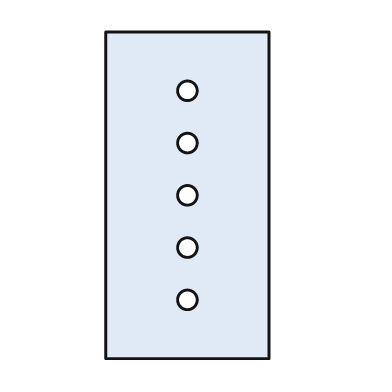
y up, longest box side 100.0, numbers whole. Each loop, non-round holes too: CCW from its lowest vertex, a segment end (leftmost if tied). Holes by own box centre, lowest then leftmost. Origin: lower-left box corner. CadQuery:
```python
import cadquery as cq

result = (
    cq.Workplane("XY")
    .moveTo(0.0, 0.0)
    .lineTo(50.0, 0.0)
    .lineTo(50.0, 100.0)
    .lineTo(0.0, 100.0)
    .close()
    .moveTo(25.0, 18.0)
    .circle(3.0)
    .moveTo(25.0, 34.0)
    .circle(3.0)
    .moveTo(25.0, 50.0)
    .circle(3.0)
    .moveTo(25.0, 66.0)
    .circle(3.0)
    .moveTo(25.0, 82.0)
    .circle(3.0)
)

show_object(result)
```